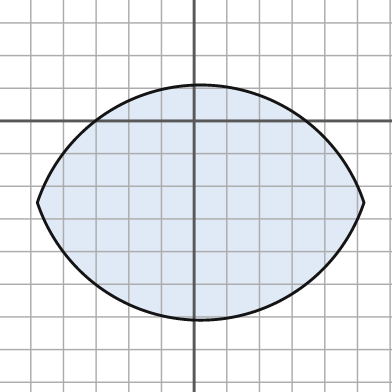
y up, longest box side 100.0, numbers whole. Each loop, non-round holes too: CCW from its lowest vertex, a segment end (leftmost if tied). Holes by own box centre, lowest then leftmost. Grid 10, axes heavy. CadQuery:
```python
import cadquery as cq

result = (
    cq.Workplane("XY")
    .moveTo(-48.0, -25.0)
    .threePointArc((2.0, -61.0), (52.0, -25.0))
    .threePointArc((2.0, 11.0), (-48.0, -25.0))
    .close()
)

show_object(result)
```